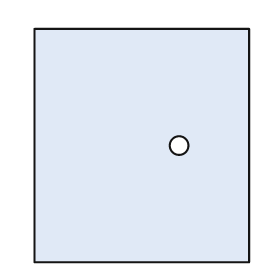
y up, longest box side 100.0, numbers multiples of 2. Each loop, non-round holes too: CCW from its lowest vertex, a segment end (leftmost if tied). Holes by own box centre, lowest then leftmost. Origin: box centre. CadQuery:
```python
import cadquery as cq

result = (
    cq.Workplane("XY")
    .moveTo(-46.0, -50.0)
    .lineTo(46.0, -50.0)
    .lineTo(46.0, 50.0)
    .lineTo(-46.0, 50.0)
    .close()
    .moveTo(16.0, 0.0)
    .circle(4.0)
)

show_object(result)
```